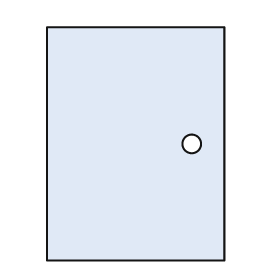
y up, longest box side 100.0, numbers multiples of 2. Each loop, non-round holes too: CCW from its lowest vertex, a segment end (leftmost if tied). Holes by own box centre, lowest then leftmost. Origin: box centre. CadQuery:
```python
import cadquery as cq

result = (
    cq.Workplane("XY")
    .moveTo(-38.0, -50.0)
    .lineTo(38.0, -50.0)
    .lineTo(38.0, 50.0)
    .lineTo(-38.0, 50.0)
    .close()
    .moveTo(24.0, 0.0)
    .circle(4.0)
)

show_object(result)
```